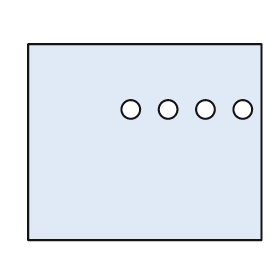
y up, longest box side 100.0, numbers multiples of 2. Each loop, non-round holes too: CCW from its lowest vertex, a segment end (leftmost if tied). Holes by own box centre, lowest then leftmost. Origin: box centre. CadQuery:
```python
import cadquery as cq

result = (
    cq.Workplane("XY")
    .moveTo(-50.0, -42.0)
    .lineTo(50.0, -42.0)
    .lineTo(50.0, 42.0)
    .lineTo(-50.0, 42.0)
    .close()
    .moveTo(-6.0, 14.0)
    .circle(4.0)
    .moveTo(10.0, 14.0)
    .circle(4.0)
    .moveTo(26.0, 14.0)
    .circle(4.0)
    .moveTo(42.0, 14.0)
    .circle(4.0)
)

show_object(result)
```